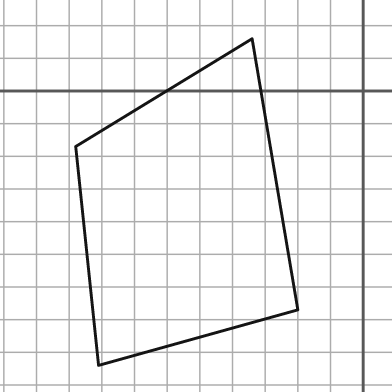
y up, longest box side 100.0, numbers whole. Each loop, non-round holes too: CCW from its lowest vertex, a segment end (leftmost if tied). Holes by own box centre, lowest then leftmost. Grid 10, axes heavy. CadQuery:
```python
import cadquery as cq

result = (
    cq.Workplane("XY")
    .moveTo(-81.0, -84.0)
    .lineTo(-20.0, -67.0)
    .lineTo(-34.0, 16.0)
    .lineTo(-88.0, -17.0)
    .close()
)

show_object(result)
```